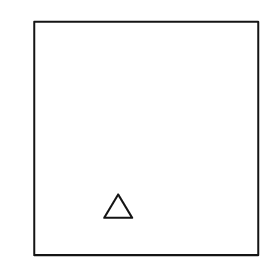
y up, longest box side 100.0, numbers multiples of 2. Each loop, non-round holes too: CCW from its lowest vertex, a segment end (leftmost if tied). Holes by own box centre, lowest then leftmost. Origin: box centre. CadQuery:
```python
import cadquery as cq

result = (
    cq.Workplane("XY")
    .moveTo(-48.0, -50.0)
    .lineTo(48.0, -50.0)
    .lineTo(48.0, 50.0)
    .lineTo(-48.0, 50.0)
    .close()
    .moveTo(-18.0, -34.0)
    .lineTo(-6.0, -34.0)
    .lineTo(-12.0, -24.0)
    .close()
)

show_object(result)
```